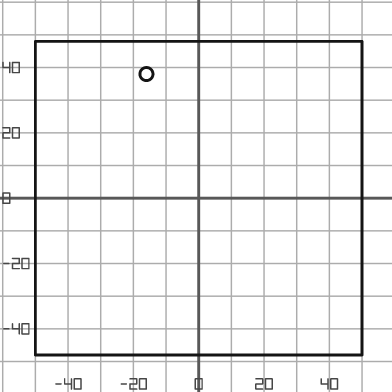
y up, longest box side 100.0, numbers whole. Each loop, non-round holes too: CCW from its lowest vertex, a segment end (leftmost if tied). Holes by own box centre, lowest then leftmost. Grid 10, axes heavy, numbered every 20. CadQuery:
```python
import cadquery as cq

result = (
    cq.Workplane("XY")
    .moveTo(-50.0, -48.0)
    .lineTo(50.0, -48.0)
    .lineTo(50.0, 48.0)
    .lineTo(-50.0, 48.0)
    .close()
    .moveTo(-16.0, 38.0)
    .circle(2.0)
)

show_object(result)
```